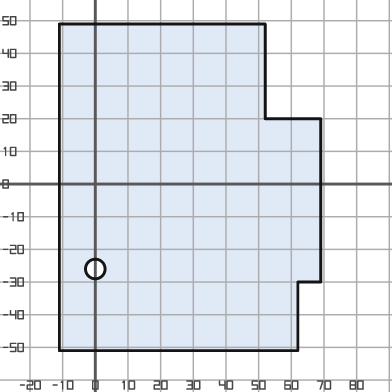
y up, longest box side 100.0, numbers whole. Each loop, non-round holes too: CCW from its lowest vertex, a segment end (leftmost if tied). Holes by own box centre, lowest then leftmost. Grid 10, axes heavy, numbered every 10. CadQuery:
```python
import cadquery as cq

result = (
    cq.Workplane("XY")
    .moveTo(-11.0, -51.0)
    .lineTo(62.0, -51.0)
    .lineTo(62.0, -30.0)
    .lineTo(69.0, -30.0)
    .lineTo(69.0, 20.0)
    .lineTo(52.0, 20.0)
    .lineTo(52.0, 49.0)
    .lineTo(-11.0, 49.0)
    .close()
    .moveTo(0.0, -26.0)
    .circle(3.0)
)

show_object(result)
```